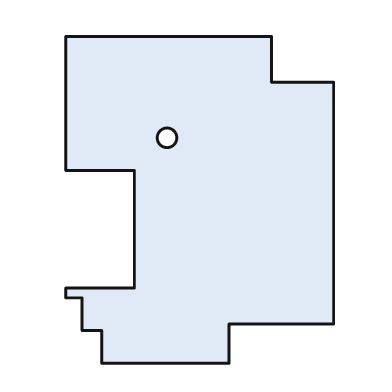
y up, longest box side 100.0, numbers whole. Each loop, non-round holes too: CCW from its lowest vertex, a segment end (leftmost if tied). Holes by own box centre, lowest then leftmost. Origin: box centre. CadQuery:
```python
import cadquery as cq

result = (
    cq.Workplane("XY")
    .moveTo(-30.0, -50.0)
    .lineTo(9.0, -50.0)
    .lineTo(9.0, -38.0)
    .lineTo(41.0, -38.0)
    .lineTo(41.0, 36.0)
    .lineTo(22.0, 36.0)
    .lineTo(22.0, 50.0)
    .lineTo(-41.0, 50.0)
    .lineTo(-41.0, 9.0)
    .lineTo(-20.0, 9.0)
    .lineTo(-20.0, -27.0)
    .lineTo(-41.0, -27.0)
    .lineTo(-41.0, -30.0)
    .lineTo(-36.0, -30.0)
    .lineTo(-36.0, -40.0)
    .lineTo(-30.0, -40.0)
    .close()
    .moveTo(-10.0, 19.0)
    .circle(3.0)
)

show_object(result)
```